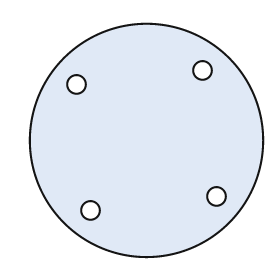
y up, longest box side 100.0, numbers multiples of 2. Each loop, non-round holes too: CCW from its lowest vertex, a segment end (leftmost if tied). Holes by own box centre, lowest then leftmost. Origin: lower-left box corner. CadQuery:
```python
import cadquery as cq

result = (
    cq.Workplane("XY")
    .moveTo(50.0, 50.0)
    .circle(50.0)
    .moveTo(26.0, 20.0)
    .circle(4.0)
    .moveTo(80.0, 26.0)
    .circle(4.0)
    .moveTo(20.0, 74.0)
    .circle(4.0)
    .moveTo(74.0, 80.0)
    .circle(4.0)
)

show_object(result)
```